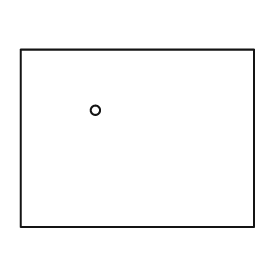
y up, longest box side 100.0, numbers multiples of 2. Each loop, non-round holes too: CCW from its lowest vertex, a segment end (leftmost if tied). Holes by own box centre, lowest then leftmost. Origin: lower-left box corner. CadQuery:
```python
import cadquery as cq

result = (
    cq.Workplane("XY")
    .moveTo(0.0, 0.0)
    .lineTo(100.0, 0.0)
    .lineTo(100.0, 76.0)
    .lineTo(0.0, 76.0)
    .close()
    .moveTo(32.0, 50.0)
    .circle(2.0)
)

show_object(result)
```